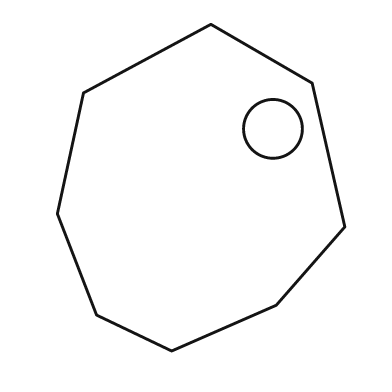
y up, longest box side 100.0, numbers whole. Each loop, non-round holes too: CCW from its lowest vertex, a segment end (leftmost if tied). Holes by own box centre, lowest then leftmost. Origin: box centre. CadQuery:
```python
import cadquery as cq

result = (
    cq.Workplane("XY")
    .moveTo(-9.0, -50.0)
    .lineTo(23.0, -36.0)
    .lineTo(44.0, -12.0)
    .lineTo(34.0, 32.0)
    .lineTo(3.0, 50.0)
    .lineTo(-36.0, 29.0)
    .lineTo(-44.0, -8.0)
    .lineTo(-32.0, -39.0)
    .close()
    .moveTo(22.0, 18.0)
    .circle(9.0)
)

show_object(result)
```